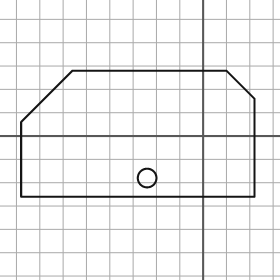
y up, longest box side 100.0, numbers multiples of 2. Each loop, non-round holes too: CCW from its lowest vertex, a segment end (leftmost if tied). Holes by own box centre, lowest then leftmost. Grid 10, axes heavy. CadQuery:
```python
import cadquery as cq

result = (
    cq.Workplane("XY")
    .moveTo(-78.0, -26.0)
    .lineTo(22.0, -26.0)
    .lineTo(22.0, 16.0)
    .lineTo(10.0, 28.0)
    .lineTo(-56.0, 28.0)
    .lineTo(-78.0, 6.0)
    .close()
    .moveTo(-24.0, -18.0)
    .circle(4.0)
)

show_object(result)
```